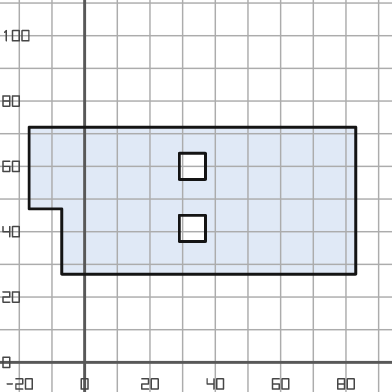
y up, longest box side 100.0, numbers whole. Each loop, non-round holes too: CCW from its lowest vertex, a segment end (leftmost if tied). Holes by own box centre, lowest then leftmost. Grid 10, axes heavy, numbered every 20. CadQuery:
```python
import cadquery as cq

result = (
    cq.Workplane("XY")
    .moveTo(-7.0, 27.0)
    .lineTo(83.0, 27.0)
    .lineTo(83.0, 72.0)
    .lineTo(-17.0, 72.0)
    .lineTo(-17.0, 47.0)
    .lineTo(-7.0, 47.0)
    .close()
    .moveTo(29.0, 37.0)
    .lineTo(37.0, 37.0)
    .lineTo(37.0, 45.0)
    .lineTo(29.0, 45.0)
    .close()
    .moveTo(29.0, 56.0)
    .lineTo(37.0, 56.0)
    .lineTo(37.0, 64.0)
    .lineTo(29.0, 64.0)
    .close()
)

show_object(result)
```